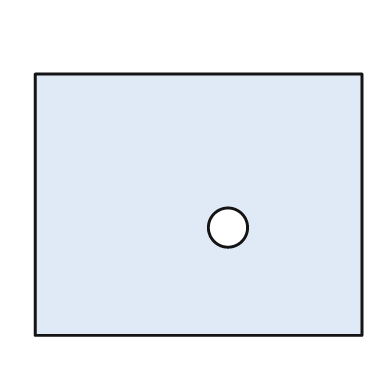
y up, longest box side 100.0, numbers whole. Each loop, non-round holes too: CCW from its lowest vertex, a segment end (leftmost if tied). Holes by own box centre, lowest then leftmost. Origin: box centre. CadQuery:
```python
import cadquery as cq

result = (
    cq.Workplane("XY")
    .moveTo(-50.0, -40.0)
    .lineTo(50.0, -40.0)
    .lineTo(50.0, 40.0)
    .lineTo(-50.0, 40.0)
    .close()
    .moveTo(9.0, -7.0)
    .circle(6.0)
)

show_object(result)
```